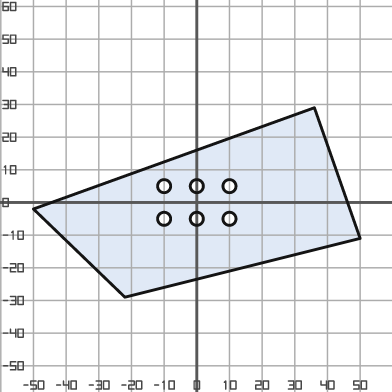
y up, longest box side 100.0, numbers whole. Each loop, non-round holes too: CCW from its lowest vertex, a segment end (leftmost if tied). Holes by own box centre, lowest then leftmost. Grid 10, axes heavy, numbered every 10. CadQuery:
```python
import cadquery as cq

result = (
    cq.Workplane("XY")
    .moveTo(-22.0, -29.0)
    .lineTo(50.0, -11.0)
    .lineTo(36.0, 29.0)
    .lineTo(-50.0, -2.0)
    .close()
    .moveTo(-10.0, -5.0)
    .circle(2.0)
    .moveTo(0.0, -5.0)
    .circle(2.0)
    .moveTo(10.0, -5.0)
    .circle(2.0)
    .moveTo(-10.0, 5.0)
    .circle(2.0)
    .moveTo(0.0, 5.0)
    .circle(2.0)
    .moveTo(10.0, 5.0)
    .circle(2.0)
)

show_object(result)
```